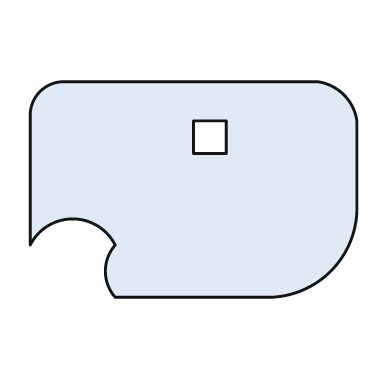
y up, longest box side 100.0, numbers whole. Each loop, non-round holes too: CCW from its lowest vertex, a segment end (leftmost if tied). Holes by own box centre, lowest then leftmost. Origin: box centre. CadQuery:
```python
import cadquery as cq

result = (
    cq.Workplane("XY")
    .moveTo(-24.0, -33.0)
    .lineTo(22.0, -33.0)
    .threePointArc((42.0, -25.0), (50.0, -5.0))
    .lineTo(50.0, 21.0)
    .threePointArc((46.0, 29.0), (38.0, 33.0))
    .lineTo(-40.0, 33.0)
    .threePointArc((-47.0, 30.0), (-50.0, 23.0))
    .lineTo(-50.0, -17.0)
    .threePointArc((-37.0, -9.0), (-24.0, -17.0))
    .threePointArc((-27.0, -25.0), (-24.0, -33.0))
    .close()
    .moveTo(0.0, 11.0)
    .lineTo(10.0, 11.0)
    .lineTo(10.0, 21.0)
    .lineTo(0.0, 21.0)
    .close()
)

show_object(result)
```